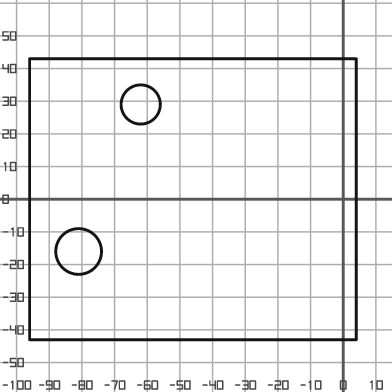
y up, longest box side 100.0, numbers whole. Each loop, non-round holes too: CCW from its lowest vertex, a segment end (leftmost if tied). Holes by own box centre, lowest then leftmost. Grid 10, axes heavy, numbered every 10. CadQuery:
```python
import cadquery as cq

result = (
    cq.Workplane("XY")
    .moveTo(-96.0, -43.0)
    .lineTo(4.0, -43.0)
    .lineTo(4.0, 43.0)
    .lineTo(-96.0, 43.0)
    .close()
    .moveTo(-81.0, -16.0)
    .circle(7.0)
    .moveTo(-62.0, 29.0)
    .circle(6.0)
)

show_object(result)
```